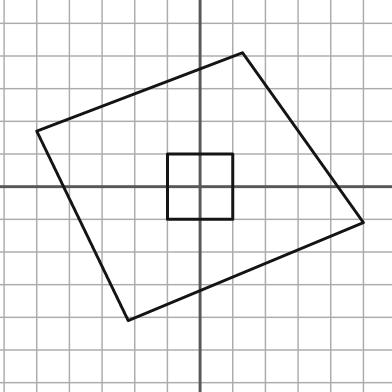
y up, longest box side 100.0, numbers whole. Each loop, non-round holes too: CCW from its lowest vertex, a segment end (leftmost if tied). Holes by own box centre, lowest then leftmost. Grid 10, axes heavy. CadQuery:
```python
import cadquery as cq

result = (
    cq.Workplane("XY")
    .moveTo(-22.0, -41.0)
    .lineTo(50.0, -11.0)
    .lineTo(13.0, 41.0)
    .lineTo(-50.0, 17.0)
    .close()
    .moveTo(-10.0, -10.0)
    .lineTo(10.0, -10.0)
    .lineTo(10.0, 10.0)
    .lineTo(-10.0, 10.0)
    .close()
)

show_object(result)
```